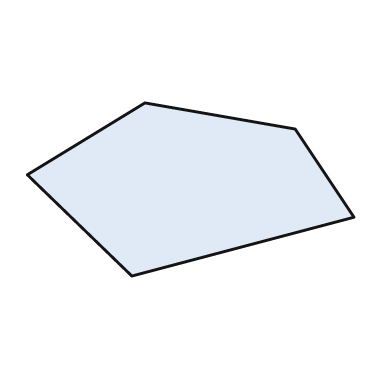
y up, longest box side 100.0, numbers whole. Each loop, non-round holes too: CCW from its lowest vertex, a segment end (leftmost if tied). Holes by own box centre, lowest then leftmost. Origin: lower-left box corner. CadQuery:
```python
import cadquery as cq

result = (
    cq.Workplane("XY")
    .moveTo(32.0, 0.0)
    .lineTo(100.0, 18.0)
    .lineTo(82.0, 45.0)
    .lineTo(36.0, 53.0)
    .lineTo(0.0, 31.0)
    .close()
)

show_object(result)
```